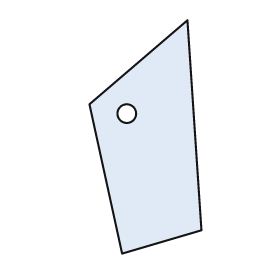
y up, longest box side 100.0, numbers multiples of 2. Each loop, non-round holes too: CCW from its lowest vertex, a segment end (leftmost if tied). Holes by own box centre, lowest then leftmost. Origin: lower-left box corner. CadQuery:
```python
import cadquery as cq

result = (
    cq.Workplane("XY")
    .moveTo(14.0, 0.0)
    .lineTo(48.0, 10.0)
    .lineTo(42.0, 100.0)
    .lineTo(0.0, 64.0)
    .close()
    .moveTo(16.0, 60.0)
    .circle(4.0)
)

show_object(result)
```